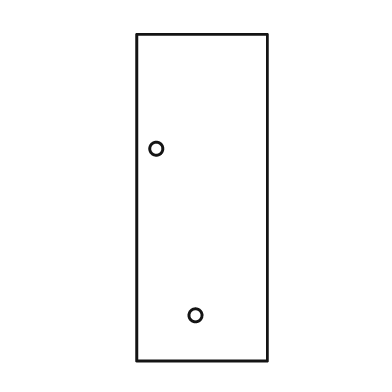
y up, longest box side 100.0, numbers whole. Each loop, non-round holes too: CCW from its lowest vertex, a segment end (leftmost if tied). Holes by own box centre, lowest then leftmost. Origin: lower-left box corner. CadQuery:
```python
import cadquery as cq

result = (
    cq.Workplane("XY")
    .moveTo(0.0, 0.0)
    .lineTo(40.0, 0.0)
    .lineTo(40.0, 100.0)
    .lineTo(0.0, 100.0)
    .close()
    .moveTo(18.0, 14.0)
    .circle(2.0)
    .moveTo(6.0, 65.0)
    .circle(2.0)
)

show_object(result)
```